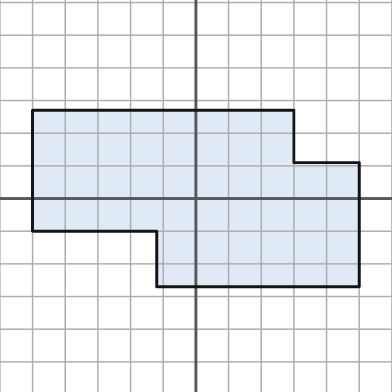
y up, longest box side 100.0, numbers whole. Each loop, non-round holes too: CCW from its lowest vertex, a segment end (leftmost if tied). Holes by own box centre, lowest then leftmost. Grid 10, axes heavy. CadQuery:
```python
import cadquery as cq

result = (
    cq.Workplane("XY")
    .moveTo(-12.0, -27.0)
    .lineTo(50.0, -27.0)
    .lineTo(50.0, 11.0)
    .lineTo(30.0, 11.0)
    .lineTo(30.0, 27.0)
    .lineTo(-50.0, 27.0)
    .lineTo(-50.0, -10.0)
    .lineTo(-12.0, -10.0)
    .close()
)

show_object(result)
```